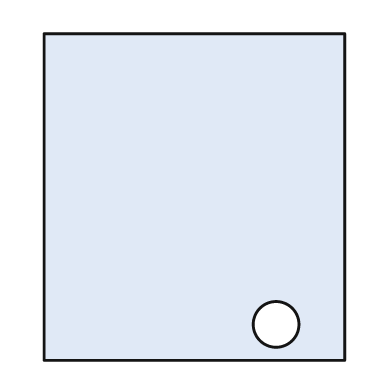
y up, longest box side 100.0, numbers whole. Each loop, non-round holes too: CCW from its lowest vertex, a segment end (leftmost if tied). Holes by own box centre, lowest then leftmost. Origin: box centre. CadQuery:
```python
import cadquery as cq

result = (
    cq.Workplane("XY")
    .moveTo(-46.0, -50.0)
    .lineTo(46.0, -50.0)
    .lineTo(46.0, 50.0)
    .lineTo(-46.0, 50.0)
    .close()
    .moveTo(25.0, -39.0)
    .circle(7.0)
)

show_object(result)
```